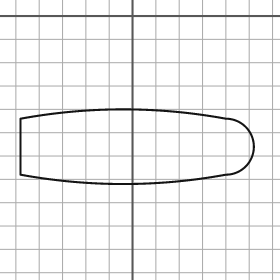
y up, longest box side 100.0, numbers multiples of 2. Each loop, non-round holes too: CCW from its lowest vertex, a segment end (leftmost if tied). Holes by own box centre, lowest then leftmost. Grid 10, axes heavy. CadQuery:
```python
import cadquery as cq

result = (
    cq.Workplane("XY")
    .moveTo(-48.0, -68.0)
    .threePointArc((-4.0, -72.0), (40.0, -68.0))
    .threePointArc((52.0, -56.0), (40.0, -44.0))
    .threePointArc((-4.0, -40.0), (-48.0, -44.0))
    .close()
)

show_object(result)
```